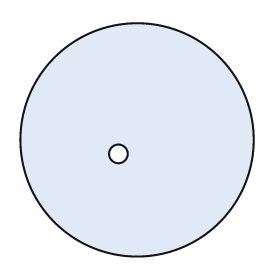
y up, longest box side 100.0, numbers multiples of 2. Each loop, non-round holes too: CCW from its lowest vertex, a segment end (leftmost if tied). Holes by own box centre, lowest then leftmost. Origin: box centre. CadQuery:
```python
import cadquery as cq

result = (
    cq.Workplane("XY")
    .moveTo(0.0, 0.0)
    .circle(50.0)
    .moveTo(-8.0, -6.0)
    .circle(4.0)
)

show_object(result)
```